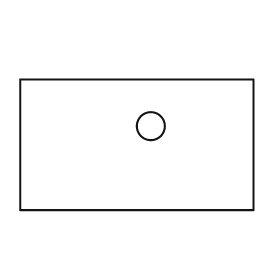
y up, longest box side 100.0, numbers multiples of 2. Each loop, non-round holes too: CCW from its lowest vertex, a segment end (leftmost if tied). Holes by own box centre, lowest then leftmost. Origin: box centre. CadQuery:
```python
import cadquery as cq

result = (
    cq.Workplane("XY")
    .moveTo(-50.0, -28.0)
    .lineTo(50.0, -28.0)
    .lineTo(50.0, 28.0)
    .lineTo(-50.0, 28.0)
    .close()
    .moveTo(6.0, 8.0)
    .circle(6.0)
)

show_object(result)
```